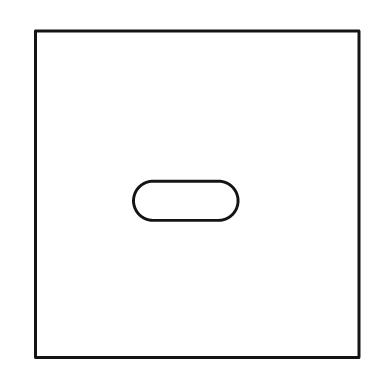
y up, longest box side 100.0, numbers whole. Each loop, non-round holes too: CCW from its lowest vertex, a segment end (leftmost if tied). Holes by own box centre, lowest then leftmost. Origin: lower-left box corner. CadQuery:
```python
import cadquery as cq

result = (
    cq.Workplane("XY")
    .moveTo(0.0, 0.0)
    .lineTo(99.0, 0.0)
    .lineTo(99.0, 100.0)
    .lineTo(0.0, 100.0)
    .close()
    .moveTo(36.0, 42.0)
    .lineTo(56.0, 42.0)
    .threePointArc((62.0, 48.0), (56.0, 54.0))
    .lineTo(36.0, 54.0)
    .threePointArc((30.0, 48.0), (36.0, 42.0))
    .close()
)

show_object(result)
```